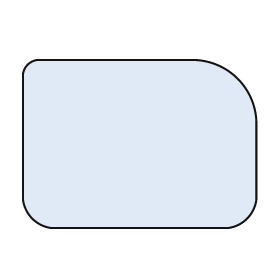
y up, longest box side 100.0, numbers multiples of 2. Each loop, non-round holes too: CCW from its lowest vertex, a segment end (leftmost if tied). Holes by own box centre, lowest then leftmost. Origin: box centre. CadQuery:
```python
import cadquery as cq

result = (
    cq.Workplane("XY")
    .moveTo(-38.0, -36.0)
    .lineTo(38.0, -36.0)
    .threePointArc((46.0, -32.0), (50.0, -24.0))
    .lineTo(50.0, 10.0)
    .threePointArc((42.0, 28.0), (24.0, 36.0))
    .lineTo(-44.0, 36.0)
    .threePointArc((-48.0, 34.0), (-50.0, 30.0))
    .lineTo(-50.0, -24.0)
    .threePointArc((-46.0, -32.0), (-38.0, -36.0))
    .close()
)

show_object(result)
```